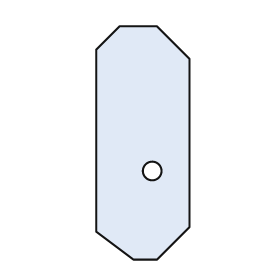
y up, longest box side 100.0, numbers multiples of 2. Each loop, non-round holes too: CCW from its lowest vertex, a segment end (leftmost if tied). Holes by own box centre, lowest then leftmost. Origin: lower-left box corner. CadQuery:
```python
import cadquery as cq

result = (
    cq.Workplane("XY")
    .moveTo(16.0, 0.0)
    .lineTo(26.0, 0.0)
    .lineTo(40.0, 14.0)
    .lineTo(40.0, 86.0)
    .lineTo(26.0, 100.0)
    .lineTo(10.0, 100.0)
    .lineTo(0.0, 90.0)
    .lineTo(0.0, 12.0)
    .close()
    .moveTo(24.0, 38.0)
    .circle(4.0)
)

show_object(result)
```